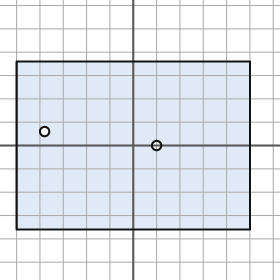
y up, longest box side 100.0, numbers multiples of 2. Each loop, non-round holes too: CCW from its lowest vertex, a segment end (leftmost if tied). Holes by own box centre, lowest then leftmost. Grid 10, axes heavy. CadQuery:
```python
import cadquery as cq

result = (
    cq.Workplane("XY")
    .moveTo(-50.0, -36.0)
    .lineTo(50.0, -36.0)
    .lineTo(50.0, 36.0)
    .lineTo(-50.0, 36.0)
    .close()
    .moveTo(10.0, 0.0)
    .circle(2.0)
    .moveTo(-38.0, 6.0)
    .circle(2.0)
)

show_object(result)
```